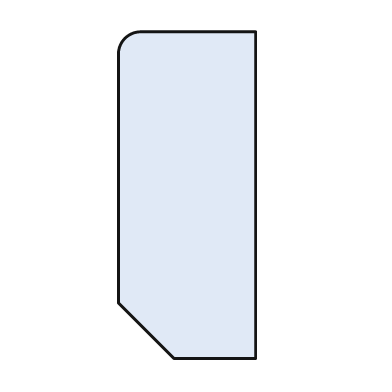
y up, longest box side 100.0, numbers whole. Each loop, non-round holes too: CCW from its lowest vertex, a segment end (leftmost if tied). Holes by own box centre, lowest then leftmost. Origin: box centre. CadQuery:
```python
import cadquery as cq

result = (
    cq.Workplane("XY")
    .moveTo(-4.0, -50.0)
    .lineTo(21.0, -50.0)
    .lineTo(21.0, 50.0)
    .lineTo(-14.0, 50.0)
    .threePointArc((-19.0, 48.0), (-21.0, 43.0))
    .lineTo(-21.0, -33.0)
    .close()
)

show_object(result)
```